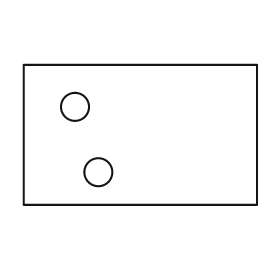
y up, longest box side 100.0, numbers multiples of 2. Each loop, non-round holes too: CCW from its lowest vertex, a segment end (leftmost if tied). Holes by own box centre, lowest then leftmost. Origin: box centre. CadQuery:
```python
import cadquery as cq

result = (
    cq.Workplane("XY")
    .moveTo(-50.0, -30.0)
    .lineTo(50.0, -30.0)
    .lineTo(50.0, 30.0)
    .lineTo(-50.0, 30.0)
    .close()
    .moveTo(-18.0, -16.0)
    .circle(6.0)
    .moveTo(-28.0, 12.0)
    .circle(6.0)
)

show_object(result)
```